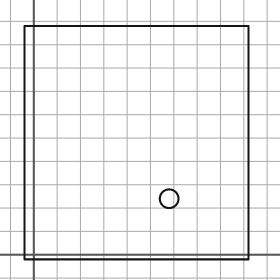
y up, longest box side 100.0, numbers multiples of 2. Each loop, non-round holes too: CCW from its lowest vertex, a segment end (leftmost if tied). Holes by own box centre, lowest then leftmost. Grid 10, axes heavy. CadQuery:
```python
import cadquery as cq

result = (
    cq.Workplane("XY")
    .moveTo(-4.0, -2.0)
    .lineTo(92.0, -2.0)
    .lineTo(92.0, 98.0)
    .lineTo(-4.0, 98.0)
    .close()
    .moveTo(58.0, 24.0)
    .circle(4.0)
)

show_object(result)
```